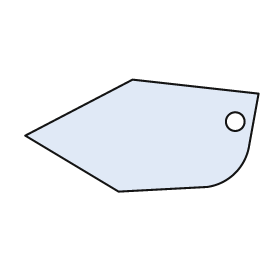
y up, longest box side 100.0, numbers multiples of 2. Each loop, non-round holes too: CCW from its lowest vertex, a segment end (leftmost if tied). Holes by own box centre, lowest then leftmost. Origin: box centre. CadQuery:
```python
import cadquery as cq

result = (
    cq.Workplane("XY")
    .moveTo(-10.0, -24.0)
    .lineTo(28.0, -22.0)
    .threePointArc((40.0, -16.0), (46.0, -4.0))
    .lineTo(50.0, 18.0)
    .lineTo(-4.0, 24.0)
    .lineTo(-50.0, 0.0)
    .close()
    .moveTo(40.0, 6.0)
    .circle(4.0)
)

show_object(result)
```